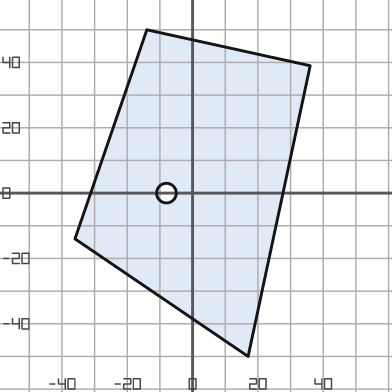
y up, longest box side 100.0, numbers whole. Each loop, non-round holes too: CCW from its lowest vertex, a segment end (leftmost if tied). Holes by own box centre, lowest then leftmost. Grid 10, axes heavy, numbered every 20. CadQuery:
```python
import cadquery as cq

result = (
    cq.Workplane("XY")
    .moveTo(17.0, -50.0)
    .lineTo(36.0, 39.0)
    .lineTo(-14.0, 50.0)
    .lineTo(-36.0, -14.0)
    .close()
    .moveTo(-8.0, 0.0)
    .circle(3.0)
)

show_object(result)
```